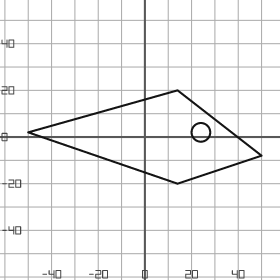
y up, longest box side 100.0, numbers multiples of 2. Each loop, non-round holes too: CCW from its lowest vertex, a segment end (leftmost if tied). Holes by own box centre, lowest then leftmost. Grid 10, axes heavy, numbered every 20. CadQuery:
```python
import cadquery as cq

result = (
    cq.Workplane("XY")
    .moveTo(14.0, -20.0)
    .lineTo(50.0, -8.0)
    .lineTo(14.0, 20.0)
    .lineTo(-50.0, 2.0)
    .close()
    .moveTo(24.0, 2.0)
    .circle(4.0)
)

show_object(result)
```